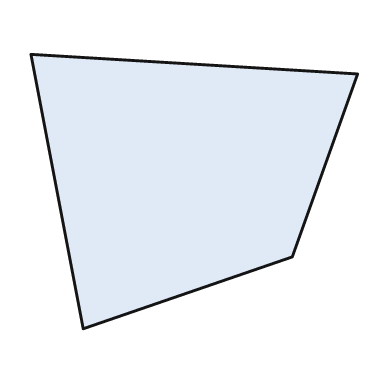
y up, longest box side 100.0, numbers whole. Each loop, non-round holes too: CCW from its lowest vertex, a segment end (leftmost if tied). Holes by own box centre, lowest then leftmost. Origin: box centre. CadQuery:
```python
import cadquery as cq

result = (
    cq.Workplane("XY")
    .moveTo(-34.0, -42.0)
    .lineTo(30.0, -20.0)
    .lineTo(50.0, 36.0)
    .lineTo(-50.0, 42.0)
    .close()
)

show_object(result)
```